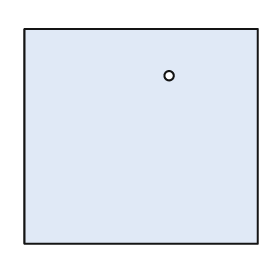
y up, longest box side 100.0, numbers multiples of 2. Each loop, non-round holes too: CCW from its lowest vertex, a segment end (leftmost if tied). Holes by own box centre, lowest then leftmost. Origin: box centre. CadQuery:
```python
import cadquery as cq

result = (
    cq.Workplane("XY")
    .moveTo(-50.0, -46.0)
    .lineTo(50.0, -46.0)
    .lineTo(50.0, 46.0)
    .lineTo(-50.0, 46.0)
    .close()
    .moveTo(12.0, 26.0)
    .circle(2.0)
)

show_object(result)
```